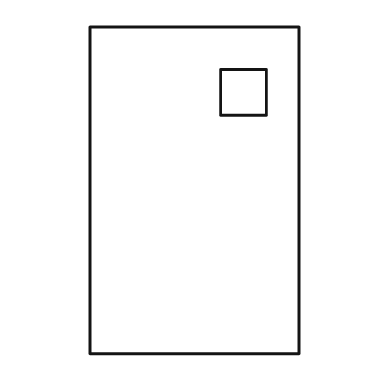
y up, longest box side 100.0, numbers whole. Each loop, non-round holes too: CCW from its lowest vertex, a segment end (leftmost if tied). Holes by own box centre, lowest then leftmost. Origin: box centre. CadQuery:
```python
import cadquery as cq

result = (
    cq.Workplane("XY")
    .moveTo(-32.0, -50.0)
    .lineTo(32.0, -50.0)
    .lineTo(32.0, 50.0)
    .lineTo(-32.0, 50.0)
    .close()
    .moveTo(8.0, 23.0)
    .lineTo(22.0, 23.0)
    .lineTo(22.0, 37.0)
    .lineTo(8.0, 37.0)
    .close()
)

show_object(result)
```